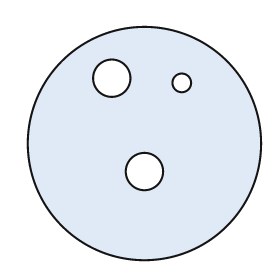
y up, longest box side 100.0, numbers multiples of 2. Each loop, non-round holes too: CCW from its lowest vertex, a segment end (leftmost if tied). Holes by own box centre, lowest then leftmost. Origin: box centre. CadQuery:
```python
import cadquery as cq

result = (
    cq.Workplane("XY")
    .moveTo(0.0, 0.0)
    .circle(50.0)
    .moveTo(0.0, -12.0)
    .circle(8.0)
    .moveTo(16.0, 26.0)
    .circle(4.0)
    .moveTo(-14.0, 28.0)
    .circle(8.0)
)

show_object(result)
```